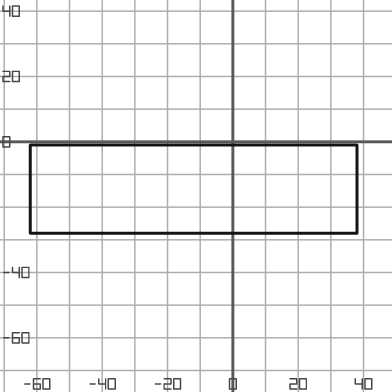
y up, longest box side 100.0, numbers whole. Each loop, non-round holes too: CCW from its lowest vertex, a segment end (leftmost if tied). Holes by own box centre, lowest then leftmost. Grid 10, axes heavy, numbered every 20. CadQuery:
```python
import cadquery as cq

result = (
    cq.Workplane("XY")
    .moveTo(-62.0, -28.0)
    .lineTo(38.0, -28.0)
    .lineTo(38.0, -1.0)
    .lineTo(-62.0, -1.0)
    .close()
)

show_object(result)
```